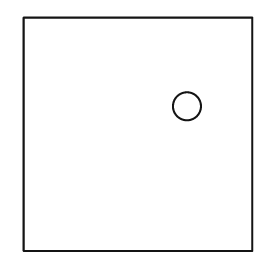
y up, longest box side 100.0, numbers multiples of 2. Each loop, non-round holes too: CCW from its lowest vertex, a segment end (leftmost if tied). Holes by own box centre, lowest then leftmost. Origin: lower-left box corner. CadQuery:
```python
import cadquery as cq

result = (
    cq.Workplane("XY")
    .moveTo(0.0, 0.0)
    .lineTo(98.0, 0.0)
    .lineTo(98.0, 100.0)
    .lineTo(0.0, 100.0)
    .close()
    .moveTo(70.0, 62.0)
    .circle(6.0)
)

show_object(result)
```